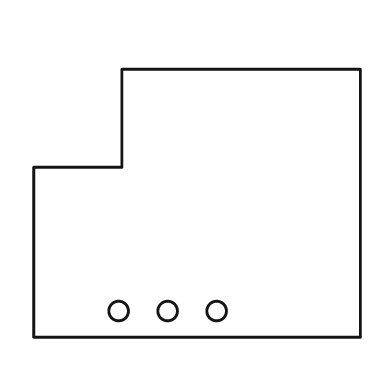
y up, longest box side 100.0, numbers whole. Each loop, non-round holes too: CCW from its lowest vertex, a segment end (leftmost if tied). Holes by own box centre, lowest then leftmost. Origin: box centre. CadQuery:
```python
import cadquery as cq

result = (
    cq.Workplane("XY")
    .moveTo(-50.0, -41.0)
    .lineTo(50.0, -41.0)
    .lineTo(50.0, 41.0)
    .lineTo(-23.0, 41.0)
    .lineTo(-23.0, 11.0)
    .lineTo(-50.0, 11.0)
    .close()
    .moveTo(-24.0, -33.0)
    .circle(3.0)
    .moveTo(-9.0, -33.0)
    .circle(3.0)
    .moveTo(6.0, -33.0)
    .circle(3.0)
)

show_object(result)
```